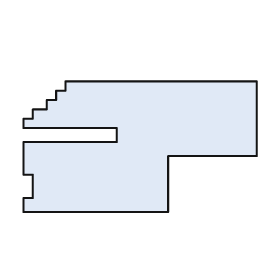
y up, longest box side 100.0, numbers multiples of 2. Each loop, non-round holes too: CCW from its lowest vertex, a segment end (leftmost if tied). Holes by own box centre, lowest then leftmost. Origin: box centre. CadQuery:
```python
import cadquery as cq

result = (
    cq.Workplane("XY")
    .moveTo(-50.0, -28.0)
    .lineTo(12.0, -28.0)
    .lineTo(12.0, -4.0)
    .lineTo(50.0, -4.0)
    .lineTo(50.0, 28.0)
    .lineTo(-32.0, 28.0)
    .lineTo(-32.0, 24.0)
    .lineTo(-36.0, 24.0)
    .lineTo(-36.0, 20.0)
    .lineTo(-40.0, 20.0)
    .lineTo(-40.0, 16.0)
    .lineTo(-46.0, 16.0)
    .lineTo(-46.0, 12.0)
    .lineTo(-50.0, 12.0)
    .lineTo(-50.0, 8.0)
    .lineTo(-10.0, 8.0)
    .lineTo(-10.0, 2.0)
    .lineTo(-50.0, 2.0)
    .lineTo(-50.0, -12.0)
    .lineTo(-46.0, -12.0)
    .lineTo(-46.0, -22.0)
    .lineTo(-50.0, -22.0)
    .close()
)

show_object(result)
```